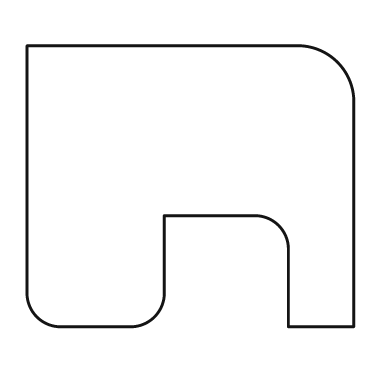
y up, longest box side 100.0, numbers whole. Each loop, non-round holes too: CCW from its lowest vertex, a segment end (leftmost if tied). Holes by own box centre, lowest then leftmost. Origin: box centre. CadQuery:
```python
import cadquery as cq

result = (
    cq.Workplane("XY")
    .moveTo(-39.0, -43.0)
    .lineTo(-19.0, -43.0)
    .threePointArc((-11.0, -40.0), (-8.0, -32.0))
    .lineTo(-8.0, -9.0)
    .lineTo(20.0, -9.0)
    .threePointArc((27.0, -12.0), (30.0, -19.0))
    .lineTo(30.0, -43.0)
    .lineTo(50.0, -43.0)
    .lineTo(50.0, 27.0)
    .threePointArc((45.0, 38.0), (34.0, 43.0))
    .lineTo(-50.0, 43.0)
    .lineTo(-50.0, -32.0)
    .threePointArc((-47.0, -40.0), (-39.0, -43.0))
    .close()
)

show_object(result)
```